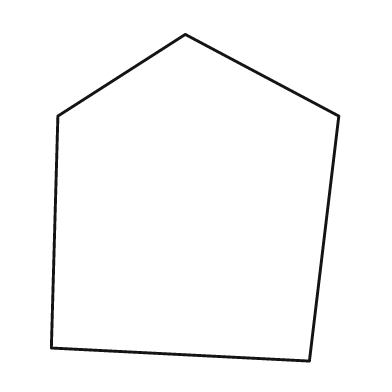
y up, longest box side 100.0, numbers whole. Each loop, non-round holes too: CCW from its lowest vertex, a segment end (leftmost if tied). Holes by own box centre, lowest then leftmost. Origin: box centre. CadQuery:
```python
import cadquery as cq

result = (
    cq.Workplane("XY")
    .moveTo(35.0, -50.0)
    .lineTo(44.0, 25.0)
    .lineTo(-3.0, 50.0)
    .lineTo(-42.0, 25.0)
    .lineTo(-44.0, -46.0)
    .close()
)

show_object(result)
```